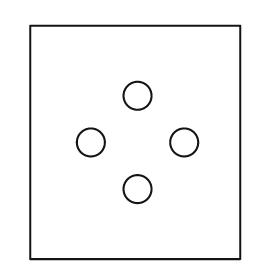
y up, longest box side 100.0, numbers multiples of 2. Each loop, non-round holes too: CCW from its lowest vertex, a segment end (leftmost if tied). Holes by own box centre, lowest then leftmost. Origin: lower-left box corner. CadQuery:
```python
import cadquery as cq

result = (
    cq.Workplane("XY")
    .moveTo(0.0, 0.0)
    .lineTo(90.0, 0.0)
    .lineTo(90.0, 100.0)
    .lineTo(0.0, 100.0)
    .close()
    .moveTo(46.0, 30.0)
    .circle(6.0)
    .moveTo(26.0, 50.0)
    .circle(6.0)
    .moveTo(66.0, 50.0)
    .circle(6.0)
    .moveTo(46.0, 70.0)
    .circle(6.0)
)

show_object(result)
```